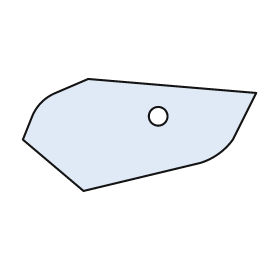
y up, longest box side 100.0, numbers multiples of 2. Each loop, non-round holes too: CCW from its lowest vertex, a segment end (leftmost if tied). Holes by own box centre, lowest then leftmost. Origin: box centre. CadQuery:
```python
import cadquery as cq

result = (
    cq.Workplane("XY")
    .moveTo(-24.0, -24.0)
    .lineTo(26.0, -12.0)
    .threePointArc((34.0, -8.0), (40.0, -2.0))
    .lineTo(50.0, 18.0)
    .lineTo(-22.0, 24.0)
    .lineTo(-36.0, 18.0)
    .threePointArc((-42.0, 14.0), (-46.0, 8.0))
    .lineTo(-50.0, -2.0)
    .close()
    .moveTo(8.0, 8.0)
    .circle(4.0)
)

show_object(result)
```